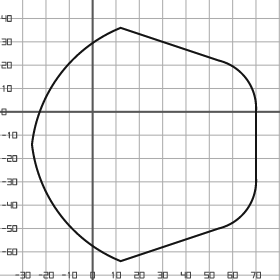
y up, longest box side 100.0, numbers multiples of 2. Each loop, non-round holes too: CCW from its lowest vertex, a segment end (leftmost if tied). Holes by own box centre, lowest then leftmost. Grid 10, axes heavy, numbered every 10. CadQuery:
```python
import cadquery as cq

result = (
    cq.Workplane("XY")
    .moveTo(12.0, -64.0)
    .lineTo(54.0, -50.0)
    .threePointArc((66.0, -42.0), (70.0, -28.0))
    .lineTo(70.0, 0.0)
    .threePointArc((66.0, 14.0), (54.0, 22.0))
    .lineTo(12.0, 36.0)
    .threePointArc((-14.0, 16.0), (-26.0, -14.0))
    .threePointArc((-14.0, -44.0), (12.0, -64.0))
    .close()
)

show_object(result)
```